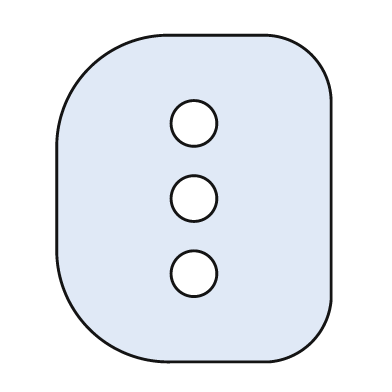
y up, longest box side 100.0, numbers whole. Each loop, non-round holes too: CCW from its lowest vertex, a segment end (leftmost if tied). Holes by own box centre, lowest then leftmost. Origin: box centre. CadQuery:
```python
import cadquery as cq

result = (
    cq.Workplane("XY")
    .moveTo(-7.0, -50.0)
    .lineTo(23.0, -50.0)
    .threePointArc((36.0, -44.0), (42.0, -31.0))
    .lineTo(42.0, 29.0)
    .threePointArc((36.0, 44.0), (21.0, 50.0))
    .lineTo(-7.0, 50.0)
    .threePointArc((-32.0, 40.0), (-42.0, 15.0))
    .lineTo(-42.0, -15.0)
    .threePointArc((-32.0, -40.0), (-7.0, -50.0))
    .close()
    .moveTo(0.0, -23.0)
    .circle(7.0)
    .moveTo(0.0, 0.0)
    .circle(7.0)
    .moveTo(0.0, 23.0)
    .circle(7.0)
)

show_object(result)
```